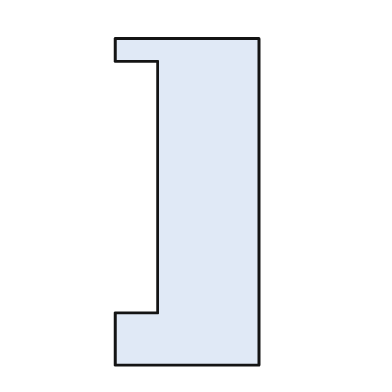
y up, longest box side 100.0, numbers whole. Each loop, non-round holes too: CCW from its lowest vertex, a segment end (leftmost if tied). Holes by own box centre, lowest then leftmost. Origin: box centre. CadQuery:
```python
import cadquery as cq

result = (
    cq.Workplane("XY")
    .moveTo(-22.0, -50.0)
    .lineTo(22.0, -50.0)
    .lineTo(22.0, 50.0)
    .lineTo(-22.0, 50.0)
    .lineTo(-22.0, 43.0)
    .lineTo(-9.0, 43.0)
    .lineTo(-9.0, -34.0)
    .lineTo(-22.0, -34.0)
    .close()
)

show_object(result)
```